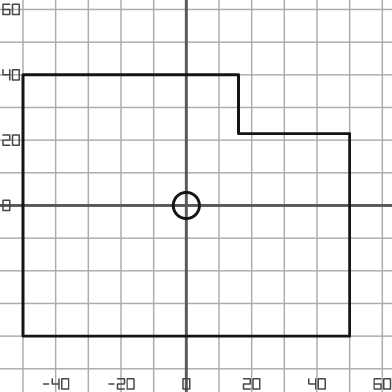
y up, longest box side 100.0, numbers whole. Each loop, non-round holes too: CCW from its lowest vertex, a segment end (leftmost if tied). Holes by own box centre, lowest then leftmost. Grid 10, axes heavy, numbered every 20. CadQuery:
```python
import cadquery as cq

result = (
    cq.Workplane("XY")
    .moveTo(-50.0, -40.0)
    .lineTo(50.0, -40.0)
    .lineTo(50.0, 22.0)
    .lineTo(16.0, 22.0)
    .lineTo(16.0, 40.0)
    .lineTo(-50.0, 40.0)
    .close()
    .moveTo(0.0, 0.0)
    .circle(4.0)
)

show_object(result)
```